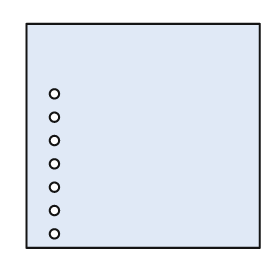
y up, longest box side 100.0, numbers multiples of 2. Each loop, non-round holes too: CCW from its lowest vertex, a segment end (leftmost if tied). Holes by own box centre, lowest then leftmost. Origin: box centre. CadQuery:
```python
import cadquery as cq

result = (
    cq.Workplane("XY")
    .moveTo(-50.0, -48.0)
    .lineTo(50.0, -48.0)
    .lineTo(50.0, 48.0)
    .lineTo(-50.0, 48.0)
    .close()
    .moveTo(-38.0, -42.0)
    .circle(2.0)
    .moveTo(-38.0, -32.0)
    .circle(2.0)
    .moveTo(-38.0, -22.0)
    .circle(2.0)
    .moveTo(-38.0, -12.0)
    .circle(2.0)
    .moveTo(-38.0, -2.0)
    .circle(2.0)
    .moveTo(-38.0, 8.0)
    .circle(2.0)
    .moveTo(-38.0, 18.0)
    .circle(2.0)
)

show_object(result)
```